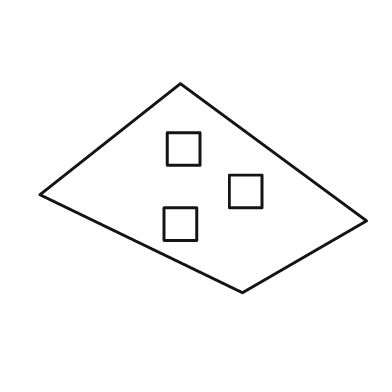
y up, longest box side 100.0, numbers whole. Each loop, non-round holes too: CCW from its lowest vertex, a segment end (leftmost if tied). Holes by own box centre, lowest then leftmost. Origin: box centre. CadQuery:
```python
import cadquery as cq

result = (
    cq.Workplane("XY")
    .moveTo(12.0, -32.0)
    .lineTo(50.0, -10.0)
    .lineTo(-7.0, 32.0)
    .lineTo(-50.0, -2.0)
    .close()
    .moveTo(-12.0, -16.0)
    .lineTo(-2.0, -16.0)
    .lineTo(-2.0, -6.0)
    .lineTo(-12.0, -6.0)
    .close()
    .moveTo(8.0, -6.0)
    .lineTo(18.0, -6.0)
    .lineTo(18.0, 4.0)
    .lineTo(8.0, 4.0)
    .close()
    .moveTo(-11.0, 7.0)
    .lineTo(-1.0, 7.0)
    .lineTo(-1.0, 17.0)
    .lineTo(-11.0, 17.0)
    .close()
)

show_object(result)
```